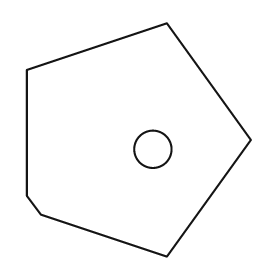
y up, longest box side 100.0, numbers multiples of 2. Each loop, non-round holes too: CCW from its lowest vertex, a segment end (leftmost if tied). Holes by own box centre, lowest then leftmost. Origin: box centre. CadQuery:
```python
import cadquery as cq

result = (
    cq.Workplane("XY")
    .moveTo(12.0, -50.0)
    .lineTo(48.0, 0.0)
    .lineTo(12.0, 50.0)
    .lineTo(-48.0, 30.0)
    .lineTo(-48.0, -24.0)
    .lineTo(-42.0, -32.0)
    .close()
    .moveTo(6.0, -4.0)
    .circle(8.0)
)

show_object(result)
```